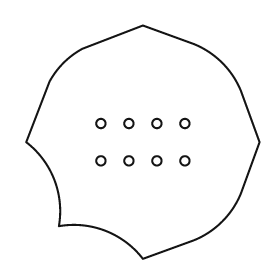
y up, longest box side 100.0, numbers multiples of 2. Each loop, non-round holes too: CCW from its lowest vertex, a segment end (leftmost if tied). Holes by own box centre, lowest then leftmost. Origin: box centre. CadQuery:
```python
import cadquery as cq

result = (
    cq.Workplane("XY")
    .moveTo(0.0, -50.0)
    .lineTo(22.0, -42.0)
    .threePointArc((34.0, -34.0), (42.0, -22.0))
    .lineTo(50.0, 0.0)
    .lineTo(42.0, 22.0)
    .threePointArc((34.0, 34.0), (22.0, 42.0))
    .lineTo(0.0, 50.0)
    .lineTo(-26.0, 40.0)
    .threePointArc((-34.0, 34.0), (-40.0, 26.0))
    .lineTo(-50.0, 0.0)
    .threePointArc((-38.0, -16.0), (-36.0, -36.0))
    .threePointArc((-16.0, -38.0), (0.0, -50.0))
    .close()
    .moveTo(-18.0, -8.0)
    .circle(2.0)
    .moveTo(-6.0, -8.0)
    .circle(2.0)
    .moveTo(6.0, -8.0)
    .circle(2.0)
    .moveTo(18.0, -8.0)
    .circle(2.0)
    .moveTo(-18.0, 8.0)
    .circle(2.0)
    .moveTo(-6.0, 8.0)
    .circle(2.0)
    .moveTo(6.0, 8.0)
    .circle(2.0)
    .moveTo(18.0, 8.0)
    .circle(2.0)
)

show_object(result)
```